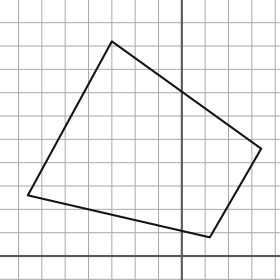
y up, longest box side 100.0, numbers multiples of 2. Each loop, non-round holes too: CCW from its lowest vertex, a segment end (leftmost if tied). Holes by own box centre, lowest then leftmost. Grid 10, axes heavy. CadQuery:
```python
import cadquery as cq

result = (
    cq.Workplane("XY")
    .moveTo(12.0, 8.0)
    .lineTo(34.0, 46.0)
    .lineTo(-30.0, 92.0)
    .lineTo(-66.0, 26.0)
    .close()
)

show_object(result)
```